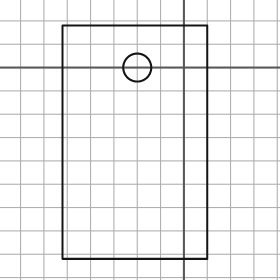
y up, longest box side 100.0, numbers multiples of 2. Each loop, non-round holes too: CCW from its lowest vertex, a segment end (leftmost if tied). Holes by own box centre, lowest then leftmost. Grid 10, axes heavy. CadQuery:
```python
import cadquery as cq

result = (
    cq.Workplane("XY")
    .moveTo(-52.0, -82.0)
    .lineTo(10.0, -82.0)
    .lineTo(10.0, 18.0)
    .lineTo(-52.0, 18.0)
    .close()
    .moveTo(-20.0, 0.0)
    .circle(6.0)
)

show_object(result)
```